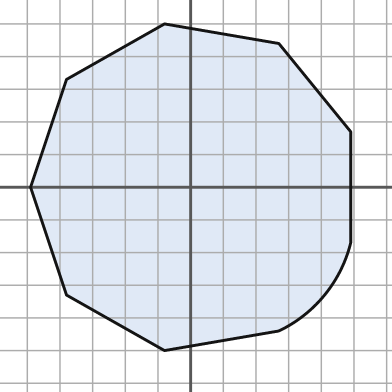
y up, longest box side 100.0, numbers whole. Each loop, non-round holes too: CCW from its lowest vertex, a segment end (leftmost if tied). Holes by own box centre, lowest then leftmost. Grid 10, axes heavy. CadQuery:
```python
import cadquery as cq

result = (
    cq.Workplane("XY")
    .moveTo(-8.0, -50.0)
    .lineTo(27.0, -44.0)
    .threePointArc((41.0, -33.0), (49.0, -17.0))
    .lineTo(49.0, 17.0)
    .lineTo(27.0, 44.0)
    .lineTo(-8.0, 50.0)
    .lineTo(-38.0, 33.0)
    .lineTo(-49.0, 0.0)
    .lineTo(-38.0, -33.0)
    .close()
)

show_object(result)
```